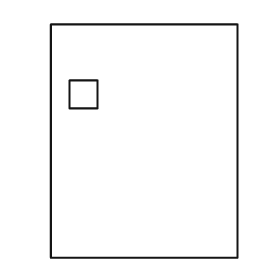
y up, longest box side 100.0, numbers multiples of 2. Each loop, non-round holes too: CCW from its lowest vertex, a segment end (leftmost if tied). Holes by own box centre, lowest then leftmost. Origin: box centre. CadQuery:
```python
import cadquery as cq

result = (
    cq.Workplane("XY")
    .moveTo(-40.0, -50.0)
    .lineTo(40.0, -50.0)
    .lineTo(40.0, 50.0)
    .lineTo(-40.0, 50.0)
    .close()
    .moveTo(-32.0, 14.0)
    .lineTo(-20.0, 14.0)
    .lineTo(-20.0, 26.0)
    .lineTo(-32.0, 26.0)
    .close()
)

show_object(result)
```